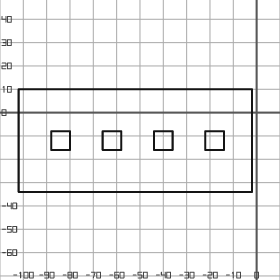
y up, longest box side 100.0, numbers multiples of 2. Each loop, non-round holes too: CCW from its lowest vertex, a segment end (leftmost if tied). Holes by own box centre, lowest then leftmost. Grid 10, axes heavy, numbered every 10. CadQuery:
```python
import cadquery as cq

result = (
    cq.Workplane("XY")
    .moveTo(-102.0, -34.0)
    .lineTo(-2.0, -34.0)
    .lineTo(-2.0, 10.0)
    .lineTo(-102.0, 10.0)
    .close()
    .moveTo(-88.0, -16.0)
    .lineTo(-80.0, -16.0)
    .lineTo(-80.0, -8.0)
    .lineTo(-88.0, -8.0)
    .close()
    .moveTo(-66.0, -16.0)
    .lineTo(-58.0, -16.0)
    .lineTo(-58.0, -8.0)
    .lineTo(-66.0, -8.0)
    .close()
    .moveTo(-44.0, -16.0)
    .lineTo(-36.0, -16.0)
    .lineTo(-36.0, -8.0)
    .lineTo(-44.0, -8.0)
    .close()
    .moveTo(-22.0, -16.0)
    .lineTo(-14.0, -16.0)
    .lineTo(-14.0, -8.0)
    .lineTo(-22.0, -8.0)
    .close()
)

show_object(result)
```